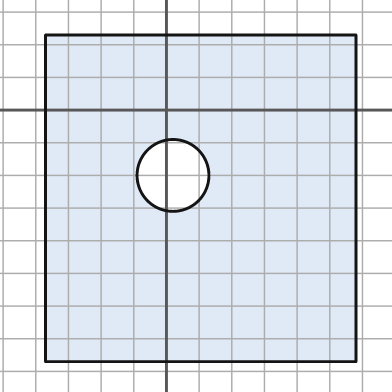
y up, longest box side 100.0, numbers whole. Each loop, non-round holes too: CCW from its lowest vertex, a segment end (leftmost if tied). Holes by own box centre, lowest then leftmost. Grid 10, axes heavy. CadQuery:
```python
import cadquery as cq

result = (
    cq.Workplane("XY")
    .moveTo(-37.0, -77.0)
    .lineTo(58.0, -77.0)
    .lineTo(58.0, 23.0)
    .lineTo(-37.0, 23.0)
    .close()
    .moveTo(2.0, -20.0)
    .circle(11.0)
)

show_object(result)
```